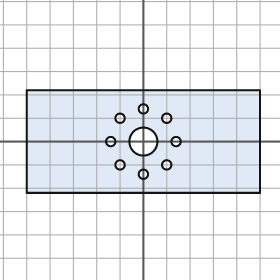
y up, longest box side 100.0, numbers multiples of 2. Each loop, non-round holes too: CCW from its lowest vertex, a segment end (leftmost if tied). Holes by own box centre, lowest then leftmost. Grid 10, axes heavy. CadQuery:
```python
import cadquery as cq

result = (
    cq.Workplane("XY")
    .moveTo(-50.0, -22.0)
    .lineTo(50.0, -22.0)
    .lineTo(50.0, 22.0)
    .lineTo(-50.0, 22.0)
    .close()
    .moveTo(0.0, -14.0)
    .circle(2.0)
    .moveTo(-10.0, -10.0)
    .circle(2.0)
    .moveTo(10.0, -10.0)
    .circle(2.0)
    .moveTo(-14.0, 0.0)
    .circle(2.0)
    .moveTo(0.0, 0.0)
    .circle(6.0)
    .moveTo(14.0, 0.0)
    .circle(2.0)
    .moveTo(-10.0, 10.0)
    .circle(2.0)
    .moveTo(10.0, 10.0)
    .circle(2.0)
    .moveTo(0.0, 14.0)
    .circle(2.0)
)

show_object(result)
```